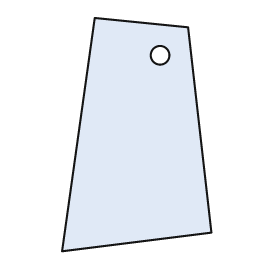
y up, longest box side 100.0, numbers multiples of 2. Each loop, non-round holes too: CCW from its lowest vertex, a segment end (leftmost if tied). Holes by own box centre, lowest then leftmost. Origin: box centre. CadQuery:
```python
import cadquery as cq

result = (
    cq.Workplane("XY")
    .moveTo(-32.0, -50.0)
    .lineTo(32.0, -42.0)
    .lineTo(22.0, 46.0)
    .lineTo(-18.0, 50.0)
    .close()
    .moveTo(10.0, 34.0)
    .circle(4.0)
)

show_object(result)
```